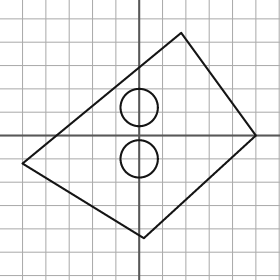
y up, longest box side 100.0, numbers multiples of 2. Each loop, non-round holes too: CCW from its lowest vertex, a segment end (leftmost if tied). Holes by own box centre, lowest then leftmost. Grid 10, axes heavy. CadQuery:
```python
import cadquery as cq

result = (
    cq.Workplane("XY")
    .moveTo(2.0, -44.0)
    .lineTo(50.0, 0.0)
    .lineTo(18.0, 44.0)
    .lineTo(-50.0, -12.0)
    .close()
    .moveTo(0.0, -10.0)
    .circle(8.0)
    .moveTo(0.0, 12.0)
    .circle(8.0)
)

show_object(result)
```